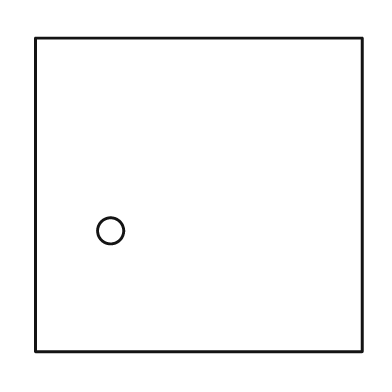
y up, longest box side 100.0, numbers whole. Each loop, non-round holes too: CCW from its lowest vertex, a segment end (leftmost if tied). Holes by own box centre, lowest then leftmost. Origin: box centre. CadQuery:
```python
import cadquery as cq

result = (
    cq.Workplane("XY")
    .moveTo(-50.0, -48.0)
    .lineTo(50.0, -48.0)
    .lineTo(50.0, 48.0)
    .lineTo(-50.0, 48.0)
    .close()
    .moveTo(-27.0, -11.0)
    .circle(4.0)
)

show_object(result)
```